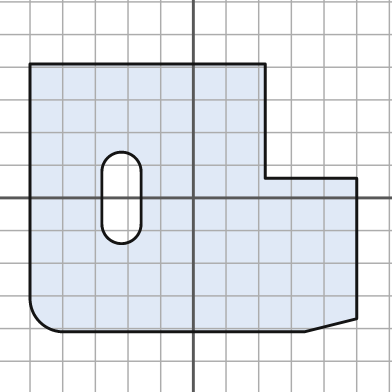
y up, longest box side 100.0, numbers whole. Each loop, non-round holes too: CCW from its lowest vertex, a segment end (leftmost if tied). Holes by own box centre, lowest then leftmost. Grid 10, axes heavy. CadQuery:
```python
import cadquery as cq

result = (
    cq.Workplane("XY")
    .moveTo(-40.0, -41.0)
    .lineTo(34.0, -41.0)
    .lineTo(50.0, -37.0)
    .lineTo(50.0, 6.0)
    .lineTo(22.0, 6.0)
    .lineTo(22.0, 41.0)
    .lineTo(-50.0, 41.0)
    .lineTo(-50.0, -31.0)
    .threePointArc((-47.0, -38.0), (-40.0, -41.0))
    .close()
    .moveTo(-28.0, -8.0)
    .threePointArc((-22.0, -14.0), (-16.0, -8.0))
    .lineTo(-16.0, 8.0)
    .threePointArc((-22.0, 14.0), (-28.0, 8.0))
    .close()
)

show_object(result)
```